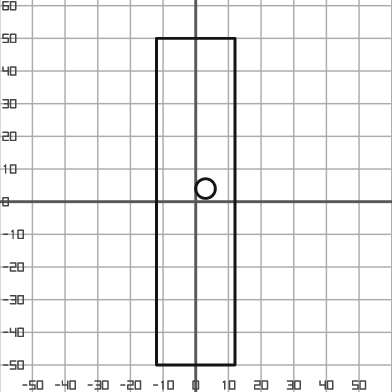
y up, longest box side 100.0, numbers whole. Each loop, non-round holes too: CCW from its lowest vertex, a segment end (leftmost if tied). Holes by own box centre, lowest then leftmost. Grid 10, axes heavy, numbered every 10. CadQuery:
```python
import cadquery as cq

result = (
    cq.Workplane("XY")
    .moveTo(-12.0, -50.0)
    .lineTo(12.0, -50.0)
    .lineTo(12.0, 50.0)
    .lineTo(-12.0, 50.0)
    .close()
    .moveTo(3.0, 4.0)
    .circle(3.0)
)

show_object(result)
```